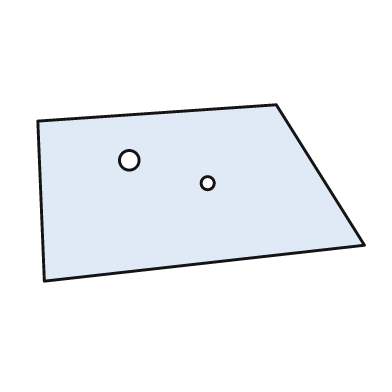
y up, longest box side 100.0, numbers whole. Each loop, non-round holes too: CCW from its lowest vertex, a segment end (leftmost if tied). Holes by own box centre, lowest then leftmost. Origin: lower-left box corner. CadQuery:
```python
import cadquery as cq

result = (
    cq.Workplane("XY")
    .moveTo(2.0, 0.0)
    .lineTo(100.0, 11.0)
    .lineTo(73.0, 54.0)
    .lineTo(0.0, 49.0)
    .close()
    .moveTo(52.0, 30.0)
    .circle(2.0)
    .moveTo(28.0, 37.0)
    .circle(3.0)
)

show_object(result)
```